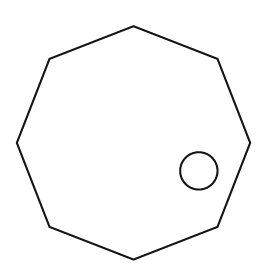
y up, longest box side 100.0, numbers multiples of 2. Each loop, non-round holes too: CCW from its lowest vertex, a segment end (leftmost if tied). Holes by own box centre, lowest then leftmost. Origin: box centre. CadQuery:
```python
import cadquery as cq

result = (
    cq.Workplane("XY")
    .moveTo(0.0, -50.0)
    .lineTo(36.0, -36.0)
    .lineTo(50.0, 0.0)
    .lineTo(36.0, 36.0)
    .lineTo(0.0, 50.0)
    .lineTo(-36.0, 36.0)
    .lineTo(-50.0, 0.0)
    .lineTo(-36.0, -36.0)
    .close()
    .moveTo(28.0, -12.0)
    .circle(8.0)
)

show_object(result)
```